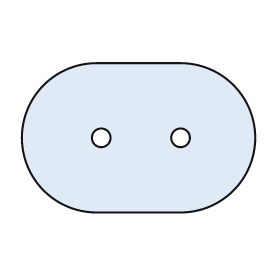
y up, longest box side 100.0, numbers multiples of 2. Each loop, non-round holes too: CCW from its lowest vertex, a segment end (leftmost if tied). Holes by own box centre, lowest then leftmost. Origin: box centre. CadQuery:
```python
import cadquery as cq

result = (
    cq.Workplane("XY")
    .moveTo(-18.0, -32.0)
    .lineTo(18.0, -32.0)
    .threePointArc((50.0, 0.0), (18.0, 32.0))
    .lineTo(-18.0, 32.0)
    .threePointArc((-50.0, 0.0), (-18.0, -32.0))
    .close()
    .moveTo(-16.0, 0.0)
    .circle(4.0)
    .moveTo(18.0, 0.0)
    .circle(4.0)
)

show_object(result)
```